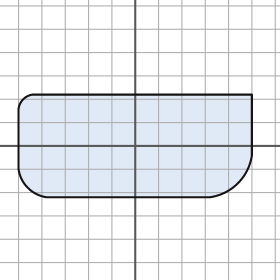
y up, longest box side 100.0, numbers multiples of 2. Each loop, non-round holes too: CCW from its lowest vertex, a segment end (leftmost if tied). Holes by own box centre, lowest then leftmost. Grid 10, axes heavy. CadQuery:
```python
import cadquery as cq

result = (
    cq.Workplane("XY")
    .moveTo(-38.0, -22.0)
    .lineTo(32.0, -22.0)
    .threePointArc((44.0, -16.0), (50.0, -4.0))
    .lineTo(50.0, 22.0)
    .lineTo(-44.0, 22.0)
    .threePointArc((-48.0, 20.0), (-50.0, 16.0))
    .lineTo(-50.0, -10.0)
    .threePointArc((-46.0, -18.0), (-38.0, -22.0))
    .close()
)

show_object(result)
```